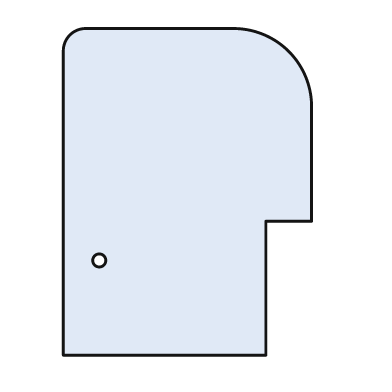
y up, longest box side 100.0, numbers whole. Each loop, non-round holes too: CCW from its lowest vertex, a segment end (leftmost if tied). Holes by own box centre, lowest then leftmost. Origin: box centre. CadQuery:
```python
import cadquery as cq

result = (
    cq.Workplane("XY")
    .moveTo(-38.0, -50.0)
    .lineTo(24.0, -50.0)
    .lineTo(24.0, -9.0)
    .lineTo(38.0, -9.0)
    .lineTo(38.0, 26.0)
    .threePointArc((31.0, 43.0), (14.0, 50.0))
    .lineTo(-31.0, 50.0)
    .threePointArc((-36.0, 48.0), (-38.0, 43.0))
    .close()
    .moveTo(-27.0, -21.0)
    .circle(2.0)
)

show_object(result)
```